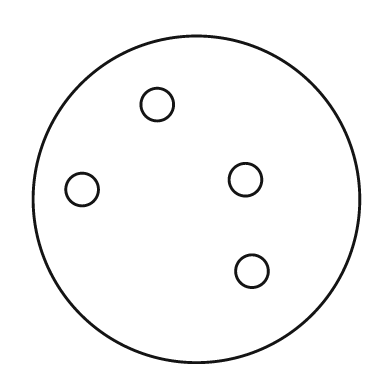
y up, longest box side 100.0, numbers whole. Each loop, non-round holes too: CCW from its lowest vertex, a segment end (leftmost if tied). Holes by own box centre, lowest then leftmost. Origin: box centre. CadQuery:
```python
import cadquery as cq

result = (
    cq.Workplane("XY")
    .moveTo(0.0, 0.0)
    .circle(50.0)
    .moveTo(17.0, -22.0)
    .circle(5.0)
    .moveTo(-35.0, 3.0)
    .circle(5.0)
    .moveTo(15.0, 6.0)
    .circle(5.0)
    .moveTo(-12.0, 29.0)
    .circle(5.0)
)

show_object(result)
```